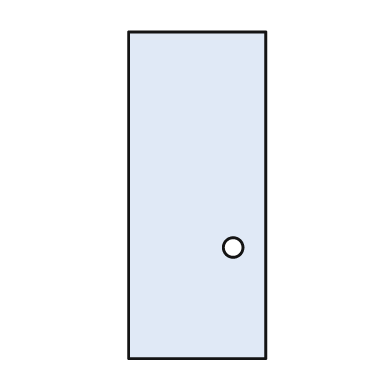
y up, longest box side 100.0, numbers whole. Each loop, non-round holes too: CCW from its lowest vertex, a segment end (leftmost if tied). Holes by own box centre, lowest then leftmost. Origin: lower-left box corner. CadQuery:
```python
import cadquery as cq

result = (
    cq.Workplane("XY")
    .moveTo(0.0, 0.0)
    .lineTo(42.0, 0.0)
    .lineTo(42.0, 100.0)
    .lineTo(0.0, 100.0)
    .close()
    .moveTo(32.0, 34.0)
    .circle(3.0)
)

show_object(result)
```